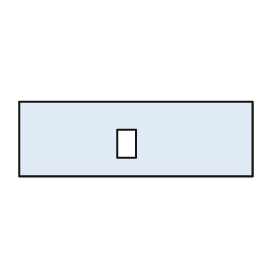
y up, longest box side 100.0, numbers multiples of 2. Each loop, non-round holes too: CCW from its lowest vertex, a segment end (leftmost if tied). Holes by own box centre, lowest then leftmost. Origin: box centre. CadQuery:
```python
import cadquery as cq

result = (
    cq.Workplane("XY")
    .moveTo(-50.0, -16.0)
    .lineTo(50.0, -16.0)
    .lineTo(50.0, 16.0)
    .lineTo(-50.0, 16.0)
    .close()
    .moveTo(-8.0, -8.0)
    .lineTo(0.0, -8.0)
    .lineTo(0.0, 4.0)
    .lineTo(-8.0, 4.0)
    .close()
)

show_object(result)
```